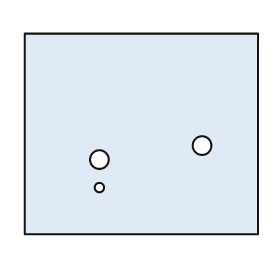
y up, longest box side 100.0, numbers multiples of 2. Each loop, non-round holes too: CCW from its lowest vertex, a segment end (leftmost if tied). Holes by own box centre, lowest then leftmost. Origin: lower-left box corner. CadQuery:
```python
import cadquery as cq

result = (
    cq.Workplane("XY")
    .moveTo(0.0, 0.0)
    .lineTo(100.0, 0.0)
    .lineTo(100.0, 86.0)
    .lineTo(0.0, 86.0)
    .close()
    .moveTo(32.0, 20.0)
    .circle(2.0)
    .moveTo(32.0, 32.0)
    .circle(4.0)
    .moveTo(76.0, 38.0)
    .circle(4.0)
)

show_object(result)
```